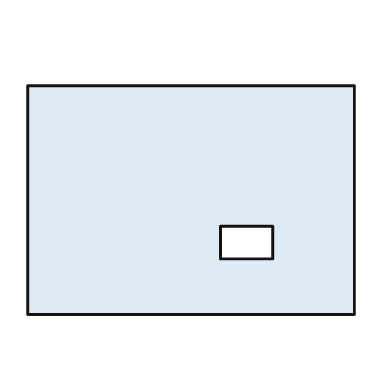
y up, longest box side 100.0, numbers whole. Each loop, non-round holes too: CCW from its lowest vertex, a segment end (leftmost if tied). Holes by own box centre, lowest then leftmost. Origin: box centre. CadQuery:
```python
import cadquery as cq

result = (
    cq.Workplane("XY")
    .moveTo(-50.0, -35.0)
    .lineTo(50.0, -35.0)
    .lineTo(50.0, 35.0)
    .lineTo(-50.0, 35.0)
    .close()
    .moveTo(9.0, -18.0)
    .lineTo(25.0, -18.0)
    .lineTo(25.0, -8.0)
    .lineTo(9.0, -8.0)
    .close()
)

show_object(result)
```